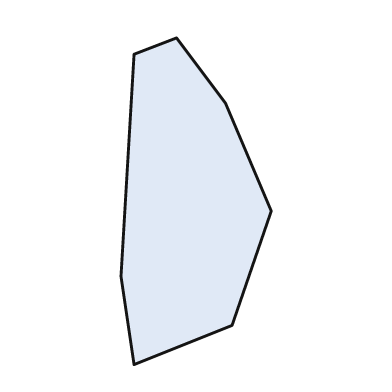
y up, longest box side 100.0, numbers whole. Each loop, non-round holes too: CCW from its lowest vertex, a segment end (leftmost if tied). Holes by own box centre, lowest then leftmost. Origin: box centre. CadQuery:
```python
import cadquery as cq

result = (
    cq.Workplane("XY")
    .moveTo(-19.0, -50.0)
    .lineTo(11.0, -38.0)
    .lineTo(23.0, -3.0)
    .lineTo(9.0, 30.0)
    .lineTo(-6.0, 50.0)
    .lineTo(-19.0, 45.0)
    .lineTo(-23.0, -23.0)
    .close()
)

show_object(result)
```